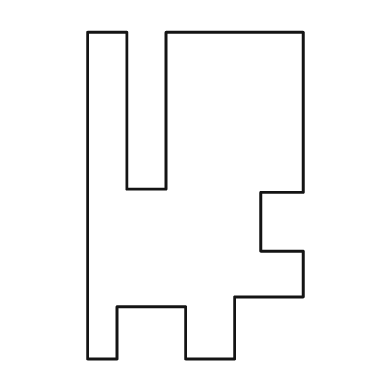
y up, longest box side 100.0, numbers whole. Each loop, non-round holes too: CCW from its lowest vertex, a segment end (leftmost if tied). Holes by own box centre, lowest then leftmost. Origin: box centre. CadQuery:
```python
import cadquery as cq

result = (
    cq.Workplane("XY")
    .moveTo(-33.0, -50.0)
    .lineTo(-24.0, -50.0)
    .lineTo(-24.0, -34.0)
    .lineTo(-3.0, -34.0)
    .lineTo(-3.0, -50.0)
    .lineTo(12.0, -50.0)
    .lineTo(12.0, -31.0)
    .lineTo(33.0, -31.0)
    .lineTo(33.0, -17.0)
    .lineTo(20.0, -17.0)
    .lineTo(20.0, 1.0)
    .lineTo(33.0, 1.0)
    .lineTo(33.0, 50.0)
    .lineTo(-9.0, 50.0)
    .lineTo(-9.0, 2.0)
    .lineTo(-21.0, 2.0)
    .lineTo(-21.0, 50.0)
    .lineTo(-33.0, 50.0)
    .close()
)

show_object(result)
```